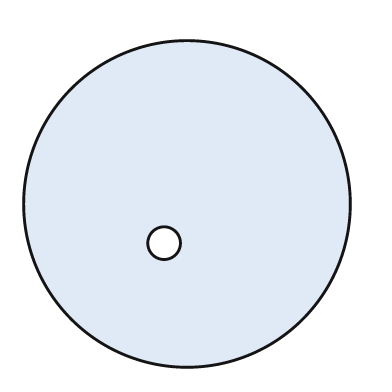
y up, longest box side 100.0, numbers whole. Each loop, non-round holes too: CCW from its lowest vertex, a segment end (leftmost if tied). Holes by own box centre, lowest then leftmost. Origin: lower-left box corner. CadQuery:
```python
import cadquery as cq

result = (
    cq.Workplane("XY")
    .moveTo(50.0, 50.0)
    .circle(50.0)
    .moveTo(43.0, 38.0)
    .circle(5.0)
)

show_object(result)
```